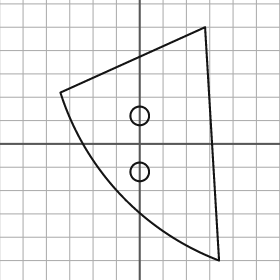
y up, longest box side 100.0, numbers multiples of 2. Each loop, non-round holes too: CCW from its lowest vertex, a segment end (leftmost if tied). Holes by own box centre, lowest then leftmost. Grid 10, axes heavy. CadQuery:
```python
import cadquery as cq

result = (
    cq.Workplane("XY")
    .moveTo(34.0, -50.0)
    .lineTo(28.0, 50.0)
    .lineTo(-34.0, 22.0)
    .threePointArc((-8.0, -22.0), (34.0, -50.0))
    .close()
    .moveTo(0.0, -12.0)
    .circle(4.0)
    .moveTo(0.0, 12.0)
    .circle(4.0)
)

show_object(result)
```